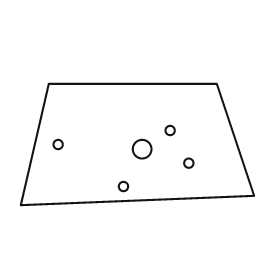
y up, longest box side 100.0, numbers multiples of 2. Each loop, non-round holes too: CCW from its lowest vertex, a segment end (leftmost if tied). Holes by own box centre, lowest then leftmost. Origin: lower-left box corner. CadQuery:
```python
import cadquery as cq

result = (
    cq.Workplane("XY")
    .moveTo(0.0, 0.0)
    .lineTo(100.0, 4.0)
    .lineTo(84.0, 52.0)
    .lineTo(12.0, 52.0)
    .close()
    .moveTo(44.0, 8.0)
    .circle(2.0)
    .moveTo(72.0, 18.0)
    .circle(2.0)
    .moveTo(52.0, 24.0)
    .circle(4.0)
    .moveTo(16.0, 26.0)
    .circle(2.0)
    .moveTo(64.0, 32.0)
    .circle(2.0)
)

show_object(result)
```